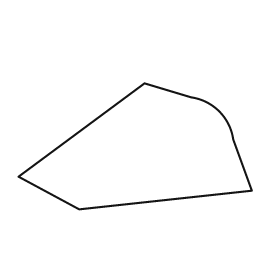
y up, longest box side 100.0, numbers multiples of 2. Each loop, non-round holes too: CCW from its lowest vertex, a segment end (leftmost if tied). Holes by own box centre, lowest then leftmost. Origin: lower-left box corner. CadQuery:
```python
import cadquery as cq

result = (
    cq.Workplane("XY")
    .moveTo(26.0, 0.0)
    .lineTo(100.0, 8.0)
    .lineTo(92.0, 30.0)
    .threePointArc((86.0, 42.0), (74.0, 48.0))
    .lineTo(54.0, 54.0)
    .lineTo(0.0, 14.0)
    .close()
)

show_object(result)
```